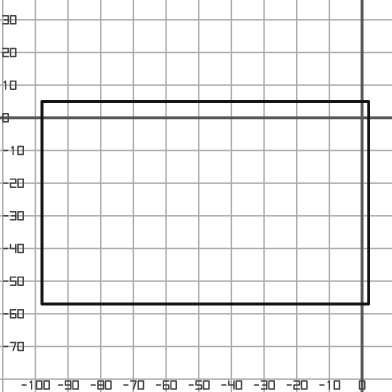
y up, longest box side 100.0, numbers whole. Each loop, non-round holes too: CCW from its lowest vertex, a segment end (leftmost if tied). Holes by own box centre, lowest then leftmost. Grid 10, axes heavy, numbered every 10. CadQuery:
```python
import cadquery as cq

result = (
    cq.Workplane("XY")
    .moveTo(-98.0, -57.0)
    .lineTo(2.0, -57.0)
    .lineTo(2.0, 5.0)
    .lineTo(-98.0, 5.0)
    .close()
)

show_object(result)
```